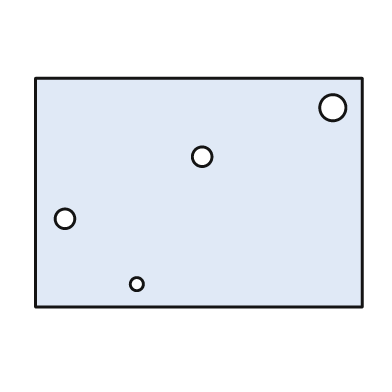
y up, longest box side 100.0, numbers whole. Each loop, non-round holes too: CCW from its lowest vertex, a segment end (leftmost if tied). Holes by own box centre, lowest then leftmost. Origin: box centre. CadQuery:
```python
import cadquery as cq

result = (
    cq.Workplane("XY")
    .moveTo(-50.0, -35.0)
    .lineTo(50.0, -35.0)
    .lineTo(50.0, 35.0)
    .lineTo(-50.0, 35.0)
    .close()
    .moveTo(-19.0, -28.0)
    .circle(2.0)
    .moveTo(-41.0, -8.0)
    .circle(3.0)
    .moveTo(1.0, 11.0)
    .circle(3.0)
    .moveTo(41.0, 26.0)
    .circle(4.0)
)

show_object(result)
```